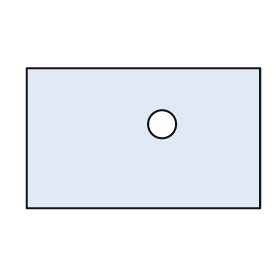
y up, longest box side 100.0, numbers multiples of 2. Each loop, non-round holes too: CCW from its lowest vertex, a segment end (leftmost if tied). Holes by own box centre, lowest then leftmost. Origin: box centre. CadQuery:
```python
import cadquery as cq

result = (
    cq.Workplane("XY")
    .moveTo(-50.0, -30.0)
    .lineTo(50.0, -30.0)
    .lineTo(50.0, 30.0)
    .lineTo(-50.0, 30.0)
    .close()
    .moveTo(8.0, 6.0)
    .circle(6.0)
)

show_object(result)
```